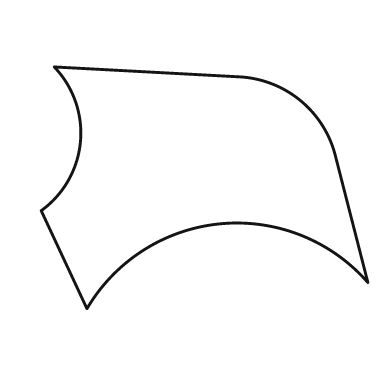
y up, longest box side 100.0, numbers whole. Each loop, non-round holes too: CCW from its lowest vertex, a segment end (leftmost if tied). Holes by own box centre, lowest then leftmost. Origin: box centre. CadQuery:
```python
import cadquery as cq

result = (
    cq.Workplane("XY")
    .moveTo(-36.0, -37.0)
    .threePointArc((5.0, -11.0), (50.0, -29.0))
    .lineTo(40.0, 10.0)
    .threePointArc((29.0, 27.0), (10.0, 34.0))
    .lineTo(-46.0, 37.0)
    .threePointArc((-38.0, 14.0), (-50.0, -7.0))
    .close()
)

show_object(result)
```